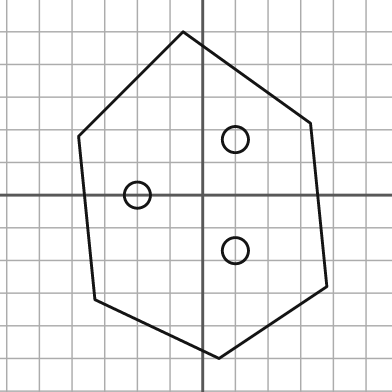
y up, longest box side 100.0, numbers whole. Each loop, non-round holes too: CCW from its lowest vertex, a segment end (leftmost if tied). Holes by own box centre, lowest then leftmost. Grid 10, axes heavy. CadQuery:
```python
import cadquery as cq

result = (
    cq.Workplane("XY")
    .moveTo(5.0, -50.0)
    .lineTo(38.0, -28.0)
    .lineTo(33.0, 22.0)
    .lineTo(-6.0, 50.0)
    .lineTo(-38.0, 18.0)
    .lineTo(-33.0, -32.0)
    .close()
    .moveTo(10.0, -17.0)
    .circle(4.0)
    .moveTo(-20.0, 0.0)
    .circle(4.0)
    .moveTo(10.0, 17.0)
    .circle(4.0)
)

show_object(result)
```